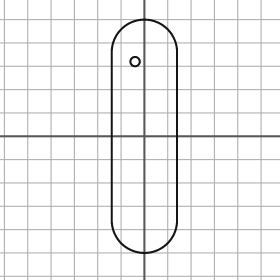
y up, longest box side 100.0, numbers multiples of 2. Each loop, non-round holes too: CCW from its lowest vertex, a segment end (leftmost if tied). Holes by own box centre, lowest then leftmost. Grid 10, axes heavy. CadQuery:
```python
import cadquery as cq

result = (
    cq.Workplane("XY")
    .moveTo(-14.0, -36.0)
    .threePointArc((0.0, -50.0), (14.0, -36.0))
    .lineTo(14.0, 36.0)
    .threePointArc((0.0, 50.0), (-14.0, 36.0))
    .close()
    .moveTo(-4.0, 32.0)
    .circle(2.0)
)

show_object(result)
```